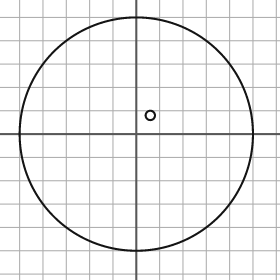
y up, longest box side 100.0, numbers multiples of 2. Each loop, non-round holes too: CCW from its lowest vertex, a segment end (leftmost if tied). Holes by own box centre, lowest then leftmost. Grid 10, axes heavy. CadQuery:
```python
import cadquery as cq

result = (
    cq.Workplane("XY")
    .moveTo(0.0, 0.0)
    .circle(50.0)
    .moveTo(6.0, 8.0)
    .circle(2.0)
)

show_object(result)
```